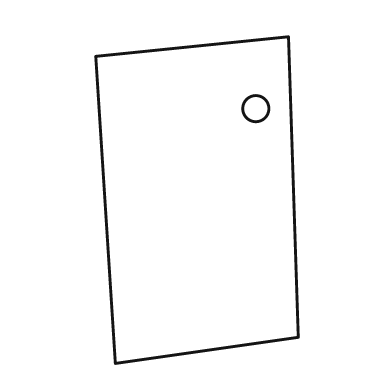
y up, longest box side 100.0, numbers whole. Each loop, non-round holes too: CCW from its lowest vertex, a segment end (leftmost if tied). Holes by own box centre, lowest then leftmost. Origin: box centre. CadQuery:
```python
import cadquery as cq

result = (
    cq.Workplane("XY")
    .moveTo(-25.0, -50.0)
    .lineTo(31.0, -42.0)
    .lineTo(28.0, 50.0)
    .lineTo(-31.0, 44.0)
    .close()
    .moveTo(18.0, 28.0)
    .circle(4.0)
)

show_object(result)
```